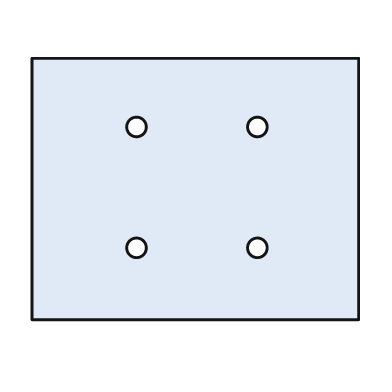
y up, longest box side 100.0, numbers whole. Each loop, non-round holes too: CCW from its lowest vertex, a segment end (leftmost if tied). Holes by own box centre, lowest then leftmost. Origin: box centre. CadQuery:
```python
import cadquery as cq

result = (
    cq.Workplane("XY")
    .moveTo(-50.0, -40.0)
    .lineTo(50.0, -40.0)
    .lineTo(50.0, 40.0)
    .lineTo(-50.0, 40.0)
    .close()
    .moveTo(-18.0, -18.0)
    .circle(3.0)
    .moveTo(19.0, -18.0)
    .circle(3.0)
    .moveTo(-18.0, 19.0)
    .circle(3.0)
    .moveTo(19.0, 19.0)
    .circle(3.0)
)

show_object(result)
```